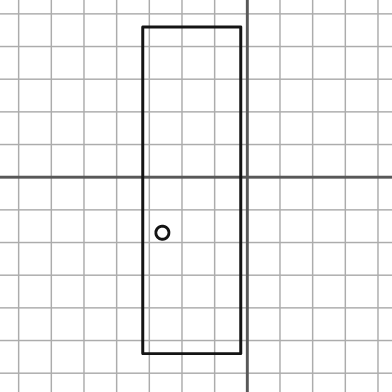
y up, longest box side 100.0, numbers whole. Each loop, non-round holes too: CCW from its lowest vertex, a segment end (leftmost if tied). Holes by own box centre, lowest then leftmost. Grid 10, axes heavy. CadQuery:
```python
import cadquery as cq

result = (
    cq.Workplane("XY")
    .moveTo(-32.0, -54.0)
    .lineTo(-2.0, -54.0)
    .lineTo(-2.0, 46.0)
    .lineTo(-32.0, 46.0)
    .close()
    .moveTo(-26.0, -17.0)
    .circle(2.0)
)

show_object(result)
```